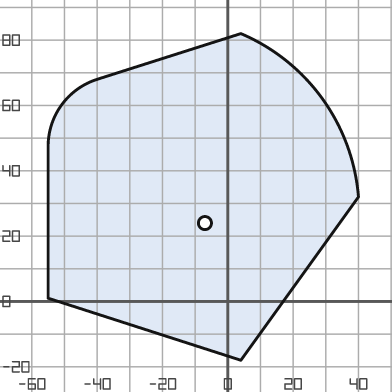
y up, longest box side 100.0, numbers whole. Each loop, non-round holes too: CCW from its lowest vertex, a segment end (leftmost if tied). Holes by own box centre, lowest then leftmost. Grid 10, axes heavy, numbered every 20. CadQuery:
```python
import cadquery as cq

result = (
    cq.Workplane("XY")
    .moveTo(4.0, -18.0)
    .lineTo(40.0, 32.0)
    .threePointArc((29.0, 62.0), (4.0, 82.0))
    .lineTo(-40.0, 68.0)
    .threePointArc((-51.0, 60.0), (-55.0, 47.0))
    .lineTo(-55.0, 1.0)
    .close()
    .moveTo(-7.0, 24.0)
    .circle(2.0)
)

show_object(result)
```